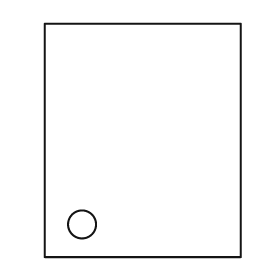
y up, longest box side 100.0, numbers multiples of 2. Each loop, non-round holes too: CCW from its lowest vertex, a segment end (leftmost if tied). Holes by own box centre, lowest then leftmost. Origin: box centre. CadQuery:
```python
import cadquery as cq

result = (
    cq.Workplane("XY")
    .moveTo(-42.0, -50.0)
    .lineTo(42.0, -50.0)
    .lineTo(42.0, 50.0)
    .lineTo(-42.0, 50.0)
    .close()
    .moveTo(-26.0, -36.0)
    .circle(6.0)
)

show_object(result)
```